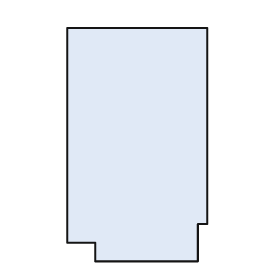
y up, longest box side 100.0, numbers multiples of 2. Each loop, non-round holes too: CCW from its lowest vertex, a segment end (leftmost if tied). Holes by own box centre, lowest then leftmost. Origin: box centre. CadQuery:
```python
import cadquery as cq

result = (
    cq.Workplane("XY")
    .moveTo(-18.0, -50.0)
    .lineTo(26.0, -50.0)
    .lineTo(26.0, -34.0)
    .lineTo(30.0, -34.0)
    .lineTo(30.0, 50.0)
    .lineTo(-30.0, 50.0)
    .lineTo(-30.0, -42.0)
    .lineTo(-18.0, -42.0)
    .close()
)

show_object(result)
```